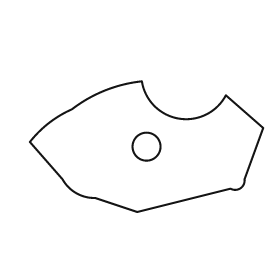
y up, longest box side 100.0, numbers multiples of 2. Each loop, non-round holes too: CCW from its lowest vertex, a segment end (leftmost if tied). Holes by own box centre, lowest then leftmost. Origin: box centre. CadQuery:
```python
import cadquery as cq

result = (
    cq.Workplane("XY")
    .moveTo(-4.0, -28.0)
    .lineTo(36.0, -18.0)
    .threePointArc((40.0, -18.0), (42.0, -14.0))
    .lineTo(50.0, 8.0)
    .lineTo(34.0, 22.0)
    .threePointArc((14.0, 12.0), (-2.0, 28.0))
    .threePointArc((-18.0, 24.0), (-32.0, 16.0))
    .threePointArc((-42.0, 10.0), (-50.0, 2.0))
    .lineTo(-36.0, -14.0)
    .threePointArc((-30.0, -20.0), (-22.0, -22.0))
    .close()
    .moveTo(0.0, 0.0)
    .circle(6.0)
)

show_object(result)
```